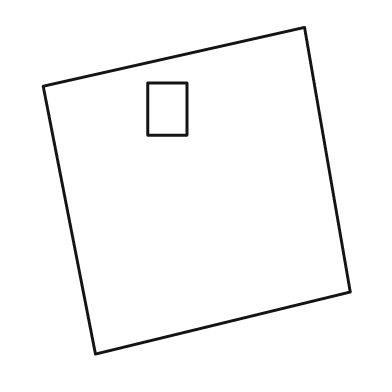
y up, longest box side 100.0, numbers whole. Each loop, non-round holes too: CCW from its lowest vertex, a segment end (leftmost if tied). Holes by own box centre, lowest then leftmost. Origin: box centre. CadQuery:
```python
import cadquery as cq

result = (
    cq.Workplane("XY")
    .moveTo(-31.0, -50.0)
    .lineTo(47.0, -31.0)
    .lineTo(33.0, 50.0)
    .lineTo(-47.0, 32.0)
    .close()
    .moveTo(-15.0, 17.0)
    .lineTo(-3.0, 17.0)
    .lineTo(-3.0, 33.0)
    .lineTo(-15.0, 33.0)
    .close()
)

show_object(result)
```